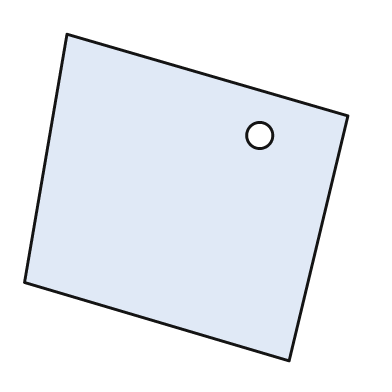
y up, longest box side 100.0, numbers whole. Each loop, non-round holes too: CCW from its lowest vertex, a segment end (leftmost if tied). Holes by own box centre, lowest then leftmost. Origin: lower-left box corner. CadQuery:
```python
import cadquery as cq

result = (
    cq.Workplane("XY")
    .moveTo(81.0, 0.0)
    .lineTo(99.0, 75.0)
    .lineTo(13.0, 100.0)
    .lineTo(0.0, 24.0)
    .close()
    .moveTo(72.0, 69.0)
    .circle(4.0)
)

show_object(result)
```